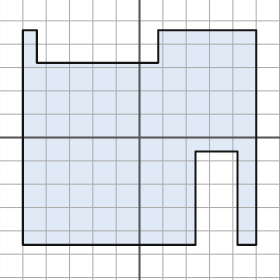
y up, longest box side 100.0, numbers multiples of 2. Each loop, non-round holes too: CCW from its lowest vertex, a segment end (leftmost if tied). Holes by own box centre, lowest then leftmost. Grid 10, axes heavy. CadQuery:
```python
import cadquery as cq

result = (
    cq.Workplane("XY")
    .moveTo(-50.0, -46.0)
    .lineTo(24.0, -46.0)
    .lineTo(24.0, -6.0)
    .lineTo(42.0, -6.0)
    .lineTo(42.0, -46.0)
    .lineTo(50.0, -46.0)
    .lineTo(50.0, 46.0)
    .lineTo(8.0, 46.0)
    .lineTo(8.0, 32.0)
    .lineTo(-44.0, 32.0)
    .lineTo(-44.0, 46.0)
    .lineTo(-50.0, 46.0)
    .close()
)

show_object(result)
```